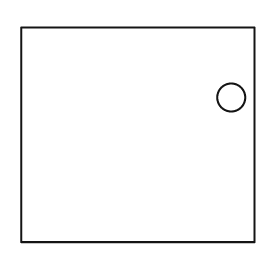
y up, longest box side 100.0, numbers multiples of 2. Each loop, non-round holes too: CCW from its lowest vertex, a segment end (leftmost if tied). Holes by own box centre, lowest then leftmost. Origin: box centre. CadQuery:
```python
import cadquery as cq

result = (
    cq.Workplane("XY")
    .moveTo(-50.0, -46.0)
    .lineTo(50.0, -46.0)
    .lineTo(50.0, 46.0)
    .lineTo(-50.0, 46.0)
    .close()
    .moveTo(40.0, 16.0)
    .circle(6.0)
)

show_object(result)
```